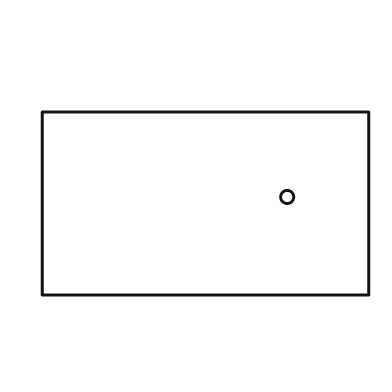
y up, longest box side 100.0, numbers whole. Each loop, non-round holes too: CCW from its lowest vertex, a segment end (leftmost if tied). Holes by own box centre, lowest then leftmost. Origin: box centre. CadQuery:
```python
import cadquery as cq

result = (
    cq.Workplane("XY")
    .moveTo(-50.0, -28.0)
    .lineTo(50.0, -28.0)
    .lineTo(50.0, 28.0)
    .lineTo(-50.0, 28.0)
    .close()
    .moveTo(25.0, 2.0)
    .circle(2.0)
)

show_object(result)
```